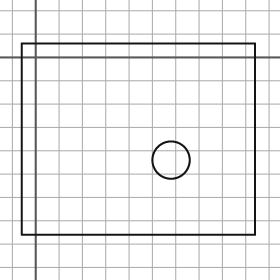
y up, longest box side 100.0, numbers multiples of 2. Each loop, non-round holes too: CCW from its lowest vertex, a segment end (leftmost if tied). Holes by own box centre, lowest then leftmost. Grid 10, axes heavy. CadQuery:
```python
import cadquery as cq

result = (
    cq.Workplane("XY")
    .moveTo(-6.0, -76.0)
    .lineTo(94.0, -76.0)
    .lineTo(94.0, 6.0)
    .lineTo(-6.0, 6.0)
    .close()
    .moveTo(58.0, -44.0)
    .circle(8.0)
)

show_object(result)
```